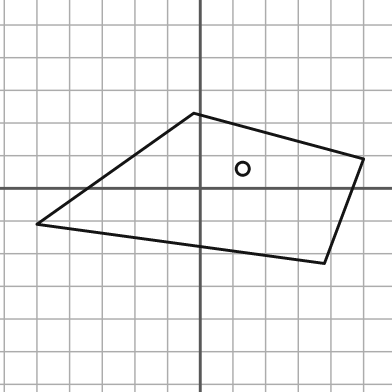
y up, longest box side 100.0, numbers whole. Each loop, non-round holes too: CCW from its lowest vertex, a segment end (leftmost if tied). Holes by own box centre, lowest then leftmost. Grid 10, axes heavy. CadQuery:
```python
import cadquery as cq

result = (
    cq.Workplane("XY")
    .moveTo(38.0, -23.0)
    .lineTo(50.0, 9.0)
    .lineTo(-2.0, 23.0)
    .lineTo(-50.0, -11.0)
    .close()
    .moveTo(13.0, 6.0)
    .circle(2.0)
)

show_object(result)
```